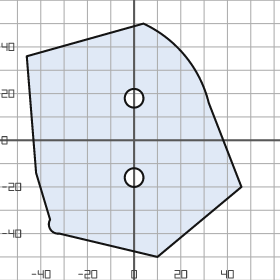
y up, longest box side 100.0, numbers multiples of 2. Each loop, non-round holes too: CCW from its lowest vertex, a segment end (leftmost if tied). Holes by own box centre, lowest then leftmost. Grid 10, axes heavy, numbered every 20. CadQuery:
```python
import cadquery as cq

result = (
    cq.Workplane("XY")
    .moveTo(10.0, -50.0)
    .lineTo(46.0, -20.0)
    .lineTo(32.0, 16.0)
    .threePointArc((22.0, 36.0), (4.0, 50.0))
    .lineTo(-46.0, 36.0)
    .lineTo(-42.0, -14.0)
    .lineTo(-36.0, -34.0)
    .threePointArc((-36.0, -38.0), (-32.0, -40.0))
    .close()
    .moveTo(0.0, -16.0)
    .circle(4.0)
    .moveTo(0.0, 18.0)
    .circle(4.0)
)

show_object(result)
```